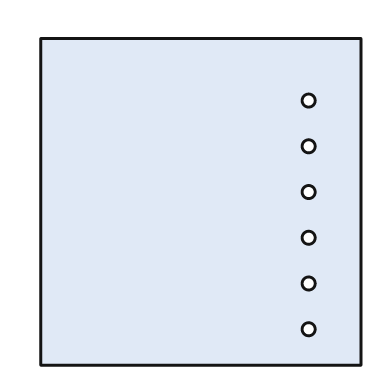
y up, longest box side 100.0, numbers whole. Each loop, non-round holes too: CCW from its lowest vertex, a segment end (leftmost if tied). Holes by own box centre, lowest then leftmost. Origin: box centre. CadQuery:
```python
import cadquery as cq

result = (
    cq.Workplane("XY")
    .moveTo(-49.0, -50.0)
    .lineTo(49.0, -50.0)
    .lineTo(49.0, 50.0)
    .lineTo(-49.0, 50.0)
    .close()
    .moveTo(33.0, -39.0)
    .circle(2.0)
    .moveTo(33.0, -25.0)
    .circle(2.0)
    .moveTo(33.0, -11.0)
    .circle(2.0)
    .moveTo(33.0, 3.0)
    .circle(2.0)
    .moveTo(33.0, 17.0)
    .circle(2.0)
    .moveTo(33.0, 31.0)
    .circle(2.0)
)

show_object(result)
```